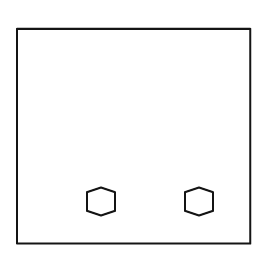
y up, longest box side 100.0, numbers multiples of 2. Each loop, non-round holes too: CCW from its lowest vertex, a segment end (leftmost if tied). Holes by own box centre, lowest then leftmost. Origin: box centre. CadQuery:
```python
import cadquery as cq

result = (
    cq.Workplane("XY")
    .moveTo(-50.0, -46.0)
    .lineTo(50.0, -46.0)
    .lineTo(50.0, 46.0)
    .lineTo(-50.0, 46.0)
    .close()
    .moveTo(-14.0, -34.0)
    .lineTo(-8.0, -32.0)
    .lineTo(-8.0, -24.0)
    .lineTo(-14.0, -22.0)
    .lineTo(-20.0, -24.0)
    .lineTo(-20.0, -32.0)
    .close()
    .moveTo(28.0, -34.0)
    .lineTo(34.0, -32.0)
    .lineTo(34.0, -24.0)
    .lineTo(28.0, -22.0)
    .lineTo(22.0, -24.0)
    .lineTo(22.0, -32.0)
    .close()
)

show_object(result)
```